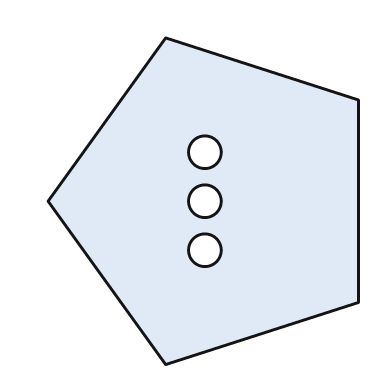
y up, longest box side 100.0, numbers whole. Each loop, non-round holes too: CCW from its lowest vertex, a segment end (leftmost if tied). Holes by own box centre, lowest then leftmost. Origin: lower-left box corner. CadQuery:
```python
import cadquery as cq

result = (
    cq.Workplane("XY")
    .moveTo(36.0, 0.0)
    .lineTo(95.0, 19.0)
    .lineTo(95.0, 81.0)
    .lineTo(36.0, 100.0)
    .lineTo(0.0, 50.0)
    .close()
    .moveTo(48.0, 35.0)
    .circle(5.0)
    .moveTo(48.0, 50.0)
    .circle(5.0)
    .moveTo(48.0, 65.0)
    .circle(5.0)
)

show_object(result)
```